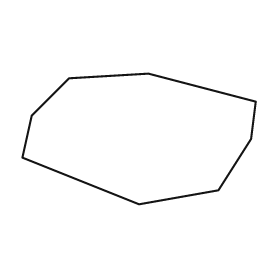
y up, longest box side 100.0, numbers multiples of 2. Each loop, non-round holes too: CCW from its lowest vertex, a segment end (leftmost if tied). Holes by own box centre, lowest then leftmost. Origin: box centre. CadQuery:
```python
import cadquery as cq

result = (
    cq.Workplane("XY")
    .moveTo(0.0, -28.0)
    .lineTo(34.0, -22.0)
    .lineTo(48.0, 0.0)
    .lineTo(50.0, 16.0)
    .lineTo(4.0, 28.0)
    .lineTo(-30.0, 26.0)
    .lineTo(-46.0, 10.0)
    .lineTo(-50.0, -8.0)
    .close()
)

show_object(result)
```